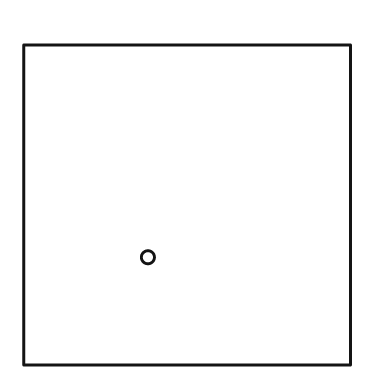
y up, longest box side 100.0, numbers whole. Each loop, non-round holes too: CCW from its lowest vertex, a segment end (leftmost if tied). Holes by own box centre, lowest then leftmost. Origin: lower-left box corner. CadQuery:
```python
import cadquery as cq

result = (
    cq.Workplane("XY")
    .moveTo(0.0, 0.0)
    .lineTo(100.0, 0.0)
    .lineTo(100.0, 98.0)
    .lineTo(0.0, 98.0)
    .close()
    .moveTo(38.0, 33.0)
    .circle(2.0)
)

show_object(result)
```